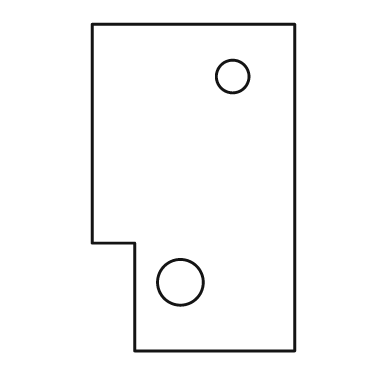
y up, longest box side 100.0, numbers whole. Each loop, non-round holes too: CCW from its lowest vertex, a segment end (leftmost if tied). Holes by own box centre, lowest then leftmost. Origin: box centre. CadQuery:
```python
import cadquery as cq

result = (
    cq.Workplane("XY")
    .moveTo(-18.0, -50.0)
    .lineTo(31.0, -50.0)
    .lineTo(31.0, 50.0)
    .lineTo(-31.0, 50.0)
    .lineTo(-31.0, -17.0)
    .lineTo(-18.0, -17.0)
    .close()
    .moveTo(-4.0, -29.0)
    .circle(7.0)
    .moveTo(12.0, 34.0)
    .circle(5.0)
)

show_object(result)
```